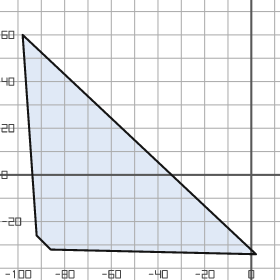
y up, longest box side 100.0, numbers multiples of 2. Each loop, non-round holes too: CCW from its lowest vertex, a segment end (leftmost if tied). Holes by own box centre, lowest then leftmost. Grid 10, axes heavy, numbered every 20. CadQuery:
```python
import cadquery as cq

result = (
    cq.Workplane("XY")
    .moveTo(2.0, -34.0)
    .lineTo(-98.0, 60.0)
    .lineTo(-92.0, -26.0)
    .lineTo(-86.0, -32.0)
    .close()
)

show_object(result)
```